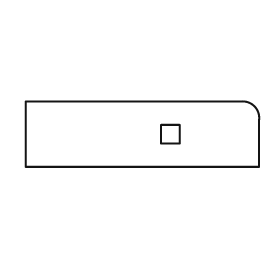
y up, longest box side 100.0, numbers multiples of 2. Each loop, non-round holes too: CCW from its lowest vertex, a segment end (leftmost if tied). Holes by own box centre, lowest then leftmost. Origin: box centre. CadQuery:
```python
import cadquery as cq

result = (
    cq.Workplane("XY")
    .moveTo(-50.0, -14.0)
    .lineTo(50.0, -14.0)
    .lineTo(50.0, 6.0)
    .threePointArc((48.0, 12.0), (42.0, 14.0))
    .lineTo(-50.0, 14.0)
    .close()
    .moveTo(8.0, -4.0)
    .lineTo(16.0, -4.0)
    .lineTo(16.0, 4.0)
    .lineTo(8.0, 4.0)
    .close()
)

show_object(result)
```